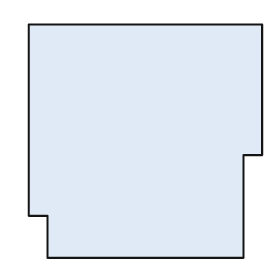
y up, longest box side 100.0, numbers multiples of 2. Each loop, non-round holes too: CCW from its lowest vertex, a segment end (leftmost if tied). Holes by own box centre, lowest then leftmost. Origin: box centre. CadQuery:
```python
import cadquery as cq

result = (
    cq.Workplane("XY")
    .moveTo(-42.0, -50.0)
    .lineTo(42.0, -50.0)
    .lineTo(42.0, -6.0)
    .lineTo(50.0, -6.0)
    .lineTo(50.0, 50.0)
    .lineTo(-50.0, 50.0)
    .lineTo(-50.0, -32.0)
    .lineTo(-42.0, -32.0)
    .close()
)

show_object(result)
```